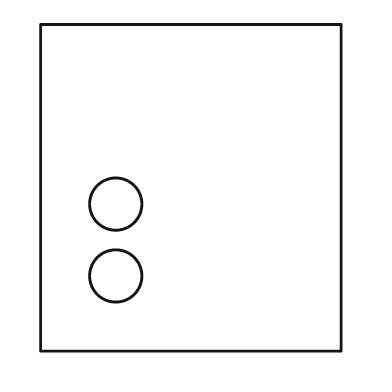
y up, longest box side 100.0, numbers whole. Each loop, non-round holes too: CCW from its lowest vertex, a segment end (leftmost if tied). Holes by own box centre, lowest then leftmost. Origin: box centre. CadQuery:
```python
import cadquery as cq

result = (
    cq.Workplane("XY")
    .moveTo(-46.0, -50.0)
    .lineTo(46.0, -50.0)
    .lineTo(46.0, 50.0)
    .lineTo(-46.0, 50.0)
    .close()
    .moveTo(-23.0, -27.0)
    .circle(8.0)
    .moveTo(-23.0, -5.0)
    .circle(8.0)
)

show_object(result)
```